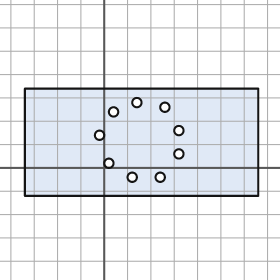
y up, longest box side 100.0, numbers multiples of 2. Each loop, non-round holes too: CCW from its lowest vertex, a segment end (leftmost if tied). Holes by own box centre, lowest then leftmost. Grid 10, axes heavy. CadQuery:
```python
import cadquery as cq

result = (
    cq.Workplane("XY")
    .moveTo(-34.0, -12.0)
    .lineTo(66.0, -12.0)
    .lineTo(66.0, 34.0)
    .lineTo(-34.0, 34.0)
    .close()
    .moveTo(12.0, -4.0)
    .circle(2.0)
    .moveTo(24.0, -4.0)
    .circle(2.0)
    .moveTo(2.0, 2.0)
    .circle(2.0)
    .moveTo(32.0, 6.0)
    .circle(2.0)
    .moveTo(-2.0, 14.0)
    .circle(2.0)
    .moveTo(32.0, 16.0)
    .circle(2.0)
    .moveTo(4.0, 24.0)
    .circle(2.0)
    .moveTo(26.0, 26.0)
    .circle(2.0)
    .moveTo(14.0, 28.0)
    .circle(2.0)
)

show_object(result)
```